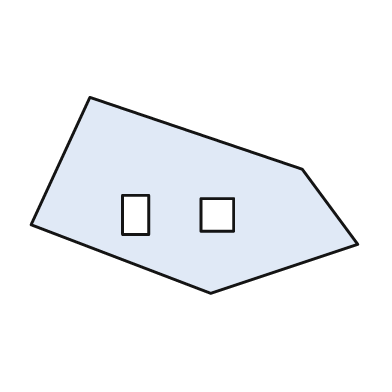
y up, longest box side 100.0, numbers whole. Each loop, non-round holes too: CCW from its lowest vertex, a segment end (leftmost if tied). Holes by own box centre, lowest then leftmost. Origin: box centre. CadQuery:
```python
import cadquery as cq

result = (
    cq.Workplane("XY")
    .moveTo(5.0, -30.0)
    .lineTo(50.0, -15.0)
    .lineTo(33.0, 8.0)
    .lineTo(-32.0, 30.0)
    .lineTo(-50.0, -9.0)
    .close()
    .moveTo(-22.0, -12.0)
    .lineTo(-14.0, -12.0)
    .lineTo(-14.0, 0.0)
    .lineTo(-22.0, 0.0)
    .close()
    .moveTo(2.0, -11.0)
    .lineTo(12.0, -11.0)
    .lineTo(12.0, -1.0)
    .lineTo(2.0, -1.0)
    .close()
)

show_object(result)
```